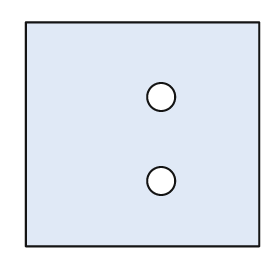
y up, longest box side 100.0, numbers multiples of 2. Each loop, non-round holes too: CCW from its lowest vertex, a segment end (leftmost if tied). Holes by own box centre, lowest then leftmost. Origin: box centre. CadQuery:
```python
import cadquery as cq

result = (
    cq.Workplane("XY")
    .moveTo(-50.0, -48.0)
    .lineTo(50.0, -48.0)
    .lineTo(50.0, 48.0)
    .lineTo(-50.0, 48.0)
    .close()
    .moveTo(8.0, -20.0)
    .circle(6.0)
    .moveTo(8.0, 16.0)
    .circle(6.0)
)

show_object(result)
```